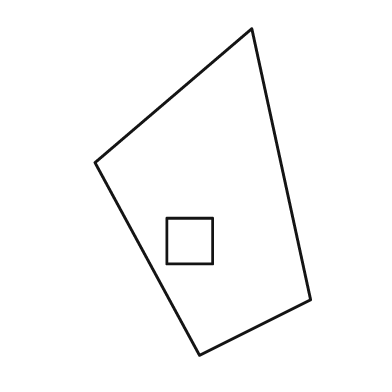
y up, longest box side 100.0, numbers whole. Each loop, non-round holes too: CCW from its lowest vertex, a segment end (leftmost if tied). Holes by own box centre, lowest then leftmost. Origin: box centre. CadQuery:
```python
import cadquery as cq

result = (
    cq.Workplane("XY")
    .moveTo(-1.0, -50.0)
    .lineTo(33.0, -33.0)
    .lineTo(15.0, 50.0)
    .lineTo(-33.0, 9.0)
    .close()
    .moveTo(-11.0, -22.0)
    .lineTo(3.0, -22.0)
    .lineTo(3.0, -8.0)
    .lineTo(-11.0, -8.0)
    .close()
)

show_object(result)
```